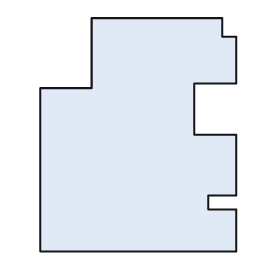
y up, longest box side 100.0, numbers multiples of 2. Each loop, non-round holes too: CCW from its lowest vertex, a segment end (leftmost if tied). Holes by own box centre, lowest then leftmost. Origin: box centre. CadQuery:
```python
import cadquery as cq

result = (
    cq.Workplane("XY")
    .moveTo(-42.0, -50.0)
    .lineTo(42.0, -50.0)
    .lineTo(42.0, -32.0)
    .lineTo(30.0, -32.0)
    .lineTo(30.0, -26.0)
    .lineTo(42.0, -26.0)
    .lineTo(42.0, 0.0)
    .lineTo(24.0, 0.0)
    .lineTo(24.0, 22.0)
    .lineTo(42.0, 22.0)
    .lineTo(42.0, 42.0)
    .lineTo(36.0, 42.0)
    .lineTo(36.0, 50.0)
    .lineTo(-20.0, 50.0)
    .lineTo(-20.0, 20.0)
    .lineTo(-42.0, 20.0)
    .close()
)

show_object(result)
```